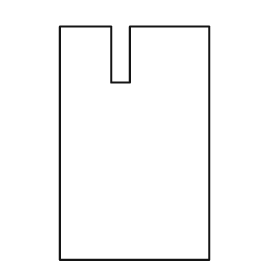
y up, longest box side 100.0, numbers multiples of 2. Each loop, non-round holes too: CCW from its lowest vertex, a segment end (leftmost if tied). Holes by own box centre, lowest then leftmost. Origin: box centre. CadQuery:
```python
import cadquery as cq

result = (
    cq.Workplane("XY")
    .moveTo(-32.0, -50.0)
    .lineTo(32.0, -50.0)
    .lineTo(32.0, 50.0)
    .lineTo(-2.0, 50.0)
    .lineTo(-2.0, 26.0)
    .lineTo(-10.0, 26.0)
    .lineTo(-10.0, 50.0)
    .lineTo(-32.0, 50.0)
    .close()
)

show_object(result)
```